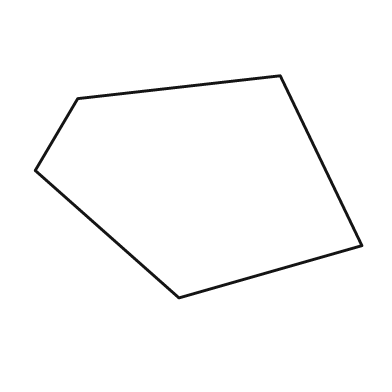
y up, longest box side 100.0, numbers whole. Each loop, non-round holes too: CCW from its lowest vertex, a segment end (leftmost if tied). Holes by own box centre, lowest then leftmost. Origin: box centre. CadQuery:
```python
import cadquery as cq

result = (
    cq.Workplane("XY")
    .moveTo(-6.0, -34.0)
    .lineTo(50.0, -18.0)
    .lineTo(25.0, 34.0)
    .lineTo(-37.0, 27.0)
    .lineTo(-50.0, 5.0)
    .close()
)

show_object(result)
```